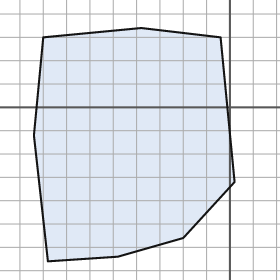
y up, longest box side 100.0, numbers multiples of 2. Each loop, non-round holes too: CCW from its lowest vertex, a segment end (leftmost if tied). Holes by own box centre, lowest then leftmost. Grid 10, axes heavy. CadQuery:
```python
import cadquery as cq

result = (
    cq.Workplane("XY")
    .moveTo(-78.0, -66.0)
    .lineTo(-48.0, -64.0)
    .lineTo(-20.0, -56.0)
    .lineTo(2.0, -32.0)
    .lineTo(-4.0, 30.0)
    .lineTo(-38.0, 34.0)
    .lineTo(-80.0, 30.0)
    .lineTo(-84.0, -12.0)
    .close()
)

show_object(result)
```